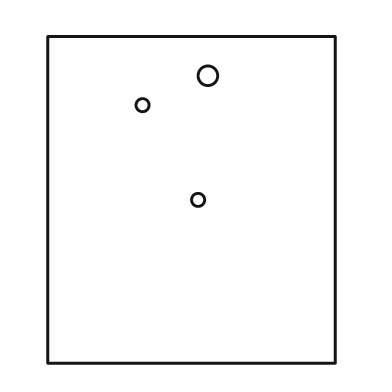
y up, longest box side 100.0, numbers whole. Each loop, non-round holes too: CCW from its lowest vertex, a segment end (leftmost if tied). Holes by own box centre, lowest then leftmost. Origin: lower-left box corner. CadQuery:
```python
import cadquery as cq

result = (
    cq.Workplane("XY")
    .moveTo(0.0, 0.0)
    .lineTo(88.0, 0.0)
    .lineTo(88.0, 100.0)
    .lineTo(0.0, 100.0)
    .close()
    .moveTo(46.0, 50.0)
    .circle(2.0)
    .moveTo(29.0, 79.0)
    .circle(2.0)
    .moveTo(49.0, 88.0)
    .circle(3.0)
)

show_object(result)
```